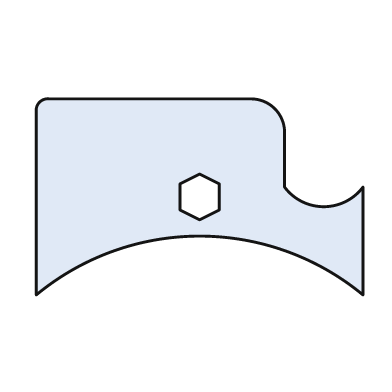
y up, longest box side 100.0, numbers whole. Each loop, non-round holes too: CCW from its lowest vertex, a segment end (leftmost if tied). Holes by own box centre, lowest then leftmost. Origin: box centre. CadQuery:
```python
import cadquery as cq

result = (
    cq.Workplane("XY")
    .moveTo(-50.0, -30.0)
    .threePointArc((0.0, -12.0), (50.0, -30.0))
    .lineTo(50.0, 3.0)
    .threePointArc((38.0, -3.0), (26.0, 3.0))
    .lineTo(26.0, 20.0)
    .threePointArc((23.0, 27.0), (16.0, 30.0))
    .lineTo(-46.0, 30.0)
    .threePointArc((-49.0, 29.0), (-50.0, 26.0))
    .close()
    .moveTo(0.0, -7.0)
    .lineTo(6.0, -4.0)
    .lineTo(6.0, 4.0)
    .lineTo(0.0, 7.0)
    .lineTo(-6.0, 4.0)
    .lineTo(-6.0, -4.0)
    .close()
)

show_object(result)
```